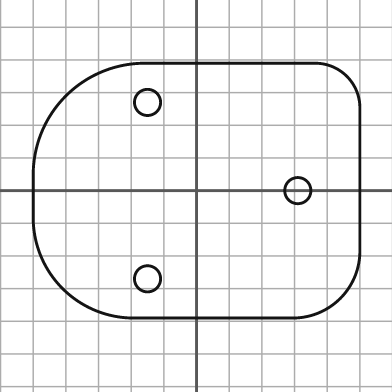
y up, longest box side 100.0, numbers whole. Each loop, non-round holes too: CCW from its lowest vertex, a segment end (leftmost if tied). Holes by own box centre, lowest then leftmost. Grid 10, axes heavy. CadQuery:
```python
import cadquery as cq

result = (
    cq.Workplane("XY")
    .moveTo(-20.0, -39.0)
    .lineTo(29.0, -39.0)
    .threePointArc((44.0, -33.0), (50.0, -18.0))
    .lineTo(50.0, 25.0)
    .threePointArc((46.0, 35.0), (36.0, 39.0))
    .lineTo(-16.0, 39.0)
    .threePointArc((-40.0, 29.0), (-50.0, 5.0))
    .lineTo(-50.0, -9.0)
    .threePointArc((-41.0, -30.0), (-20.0, -39.0))
    .close()
    .moveTo(-15.0, -27.0)
    .circle(4.0)
    .moveTo(31.0, 0.0)
    .circle(4.0)
    .moveTo(-15.0, 27.0)
    .circle(4.0)
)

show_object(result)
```